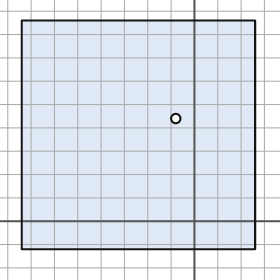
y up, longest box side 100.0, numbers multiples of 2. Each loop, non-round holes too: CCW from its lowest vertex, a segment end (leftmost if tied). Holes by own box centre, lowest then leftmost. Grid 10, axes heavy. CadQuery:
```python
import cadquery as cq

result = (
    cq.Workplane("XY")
    .moveTo(-74.0, -12.0)
    .lineTo(26.0, -12.0)
    .lineTo(26.0, 86.0)
    .lineTo(-74.0, 86.0)
    .close()
    .moveTo(-8.0, 44.0)
    .circle(2.0)
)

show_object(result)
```